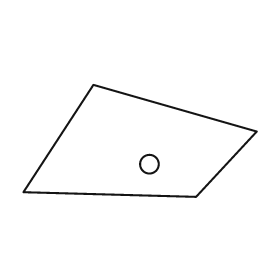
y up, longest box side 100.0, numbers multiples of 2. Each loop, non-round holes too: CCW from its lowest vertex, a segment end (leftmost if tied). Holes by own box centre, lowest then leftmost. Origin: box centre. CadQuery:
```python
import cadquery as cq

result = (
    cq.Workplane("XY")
    .moveTo(24.0, -24.0)
    .lineTo(50.0, 4.0)
    .lineTo(-20.0, 24.0)
    .lineTo(-50.0, -22.0)
    .close()
    .moveTo(4.0, -10.0)
    .circle(4.0)
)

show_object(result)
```